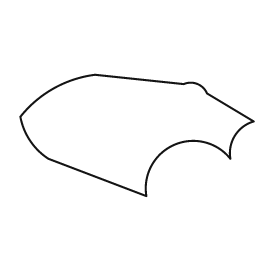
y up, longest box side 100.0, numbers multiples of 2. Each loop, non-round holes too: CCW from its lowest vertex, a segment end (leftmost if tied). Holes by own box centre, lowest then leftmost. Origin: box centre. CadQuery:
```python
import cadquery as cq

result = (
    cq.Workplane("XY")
    .moveTo(4.0, -26.0)
    .threePointArc((16.0, -4.0), (40.0, -10.0))
    .threePointArc((42.0, 0.0), (50.0, 6.0))
    .lineTo(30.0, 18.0)
    .threePointArc((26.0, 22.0), (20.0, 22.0))
    .lineTo(-18.0, 26.0)
    .threePointArc((-36.0, 20.0), (-50.0, 8.0))
    .threePointArc((-46.0, -2.0), (-38.0, -10.0))
    .close()
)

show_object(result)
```